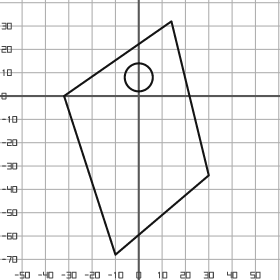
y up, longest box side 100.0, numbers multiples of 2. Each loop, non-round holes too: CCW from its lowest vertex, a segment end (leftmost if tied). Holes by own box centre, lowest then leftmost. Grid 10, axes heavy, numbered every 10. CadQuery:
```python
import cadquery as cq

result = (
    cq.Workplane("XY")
    .moveTo(-10.0, -68.0)
    .lineTo(30.0, -34.0)
    .lineTo(14.0, 32.0)
    .lineTo(-32.0, 0.0)
    .close()
    .moveTo(0.0, 8.0)
    .circle(6.0)
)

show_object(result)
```